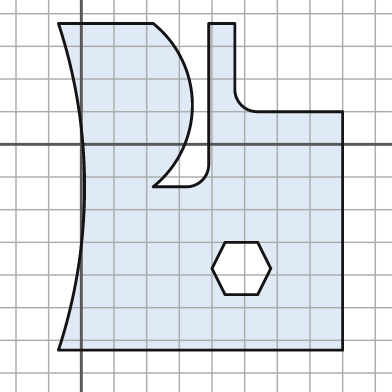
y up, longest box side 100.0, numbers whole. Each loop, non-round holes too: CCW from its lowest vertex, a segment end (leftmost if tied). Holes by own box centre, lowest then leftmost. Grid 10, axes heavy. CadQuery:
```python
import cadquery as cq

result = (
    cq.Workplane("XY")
    .moveTo(-7.0, -63.0)
    .lineTo(80.0, -63.0)
    .lineTo(80.0, 10.0)
    .lineTo(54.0, 10.0)
    .threePointArc((49.0, 12.0), (47.0, 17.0))
    .lineTo(47.0, 37.0)
    .lineTo(39.0, 37.0)
    .lineTo(39.0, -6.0)
    .threePointArc((37.0, -11.0), (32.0, -13.0))
    .lineTo(22.0, -13.0)
    .threePointArc((34.0, 12.0), (22.0, 37.0))
    .lineTo(-7.0, 37.0)
    .threePointArc((1.0, -13.0), (-7.0, -63.0))
    .close()
    .moveTo(44.0, -46.0)
    .lineTo(54.0, -46.0)
    .lineTo(58.0, -38.0)
    .lineTo(54.0, -30.0)
    .lineTo(44.0, -30.0)
    .lineTo(40.0, -38.0)
    .close()
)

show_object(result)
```